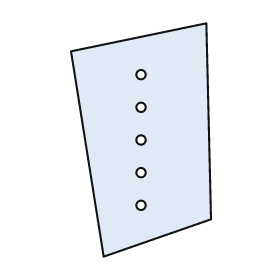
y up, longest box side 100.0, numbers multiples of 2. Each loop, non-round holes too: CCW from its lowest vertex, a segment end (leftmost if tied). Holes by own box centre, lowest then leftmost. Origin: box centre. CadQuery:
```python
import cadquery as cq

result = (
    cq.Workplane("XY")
    .moveTo(-16.0, -50.0)
    .lineTo(30.0, -34.0)
    .lineTo(28.0, 50.0)
    .lineTo(-30.0, 38.0)
    .close()
    .moveTo(0.0, -28.0)
    .circle(2.0)
    .moveTo(0.0, -14.0)
    .circle(2.0)
    .moveTo(0.0, 0.0)
    .circle(2.0)
    .moveTo(0.0, 14.0)
    .circle(2.0)
    .moveTo(0.0, 28.0)
    .circle(2.0)
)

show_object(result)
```